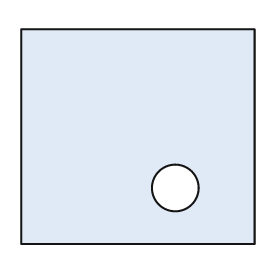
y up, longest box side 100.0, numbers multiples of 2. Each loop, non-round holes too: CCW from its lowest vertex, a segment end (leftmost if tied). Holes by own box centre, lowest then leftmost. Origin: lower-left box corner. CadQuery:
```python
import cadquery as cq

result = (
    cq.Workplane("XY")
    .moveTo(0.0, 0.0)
    .lineTo(100.0, 0.0)
    .lineTo(100.0, 92.0)
    .lineTo(0.0, 92.0)
    .close()
    .moveTo(66.0, 24.0)
    .circle(10.0)
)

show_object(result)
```